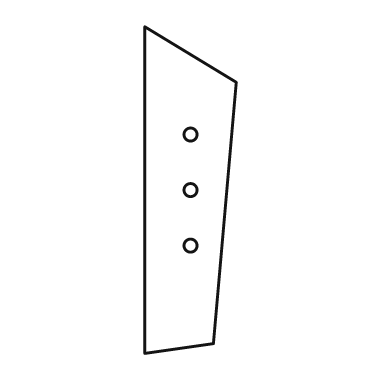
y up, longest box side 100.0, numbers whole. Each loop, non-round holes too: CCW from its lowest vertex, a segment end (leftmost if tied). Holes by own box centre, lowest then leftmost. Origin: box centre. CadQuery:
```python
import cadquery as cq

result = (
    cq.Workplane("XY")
    .moveTo(-14.0, -50.0)
    .lineTo(7.0, -47.0)
    .lineTo(14.0, 33.0)
    .lineTo(-14.0, 50.0)
    .close()
    .moveTo(0.0, -17.0)
    .circle(2.0)
    .moveTo(0.0, 0.0)
    .circle(2.0)
    .moveTo(0.0, 17.0)
    .circle(2.0)
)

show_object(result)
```